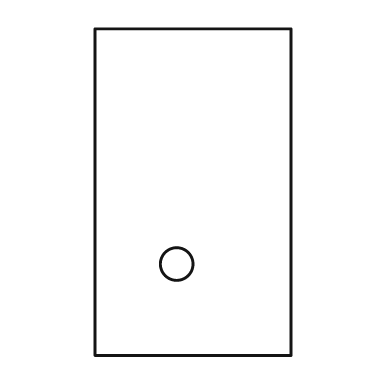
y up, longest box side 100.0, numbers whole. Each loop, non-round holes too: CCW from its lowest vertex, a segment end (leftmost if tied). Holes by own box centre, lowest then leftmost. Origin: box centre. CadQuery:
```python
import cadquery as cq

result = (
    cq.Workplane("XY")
    .moveTo(-30.0, -50.0)
    .lineTo(30.0, -50.0)
    .lineTo(30.0, 50.0)
    .lineTo(-30.0, 50.0)
    .close()
    .moveTo(-5.0, -22.0)
    .circle(5.0)
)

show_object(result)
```